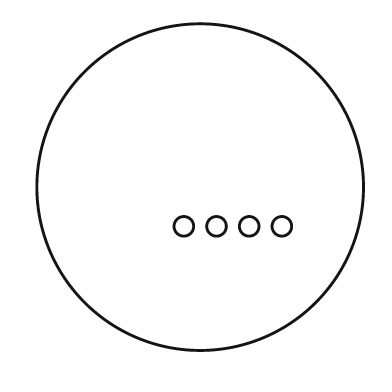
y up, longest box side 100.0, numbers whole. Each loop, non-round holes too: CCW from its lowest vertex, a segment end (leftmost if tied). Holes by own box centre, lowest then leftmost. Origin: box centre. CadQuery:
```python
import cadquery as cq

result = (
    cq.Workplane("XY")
    .moveTo(0.0, 0.0)
    .circle(50.0)
    .moveTo(-5.0, -12.0)
    .circle(3.0)
    .moveTo(5.0, -12.0)
    .circle(3.0)
    .moveTo(15.0, -12.0)
    .circle(3.0)
    .moveTo(25.0, -12.0)
    .circle(3.0)
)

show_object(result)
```